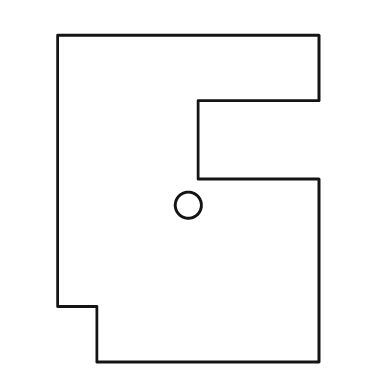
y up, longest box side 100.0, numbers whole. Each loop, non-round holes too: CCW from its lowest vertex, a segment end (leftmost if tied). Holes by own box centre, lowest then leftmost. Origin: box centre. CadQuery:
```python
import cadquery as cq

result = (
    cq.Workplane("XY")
    .moveTo(-28.0, -50.0)
    .lineTo(40.0, -50.0)
    .lineTo(40.0, 6.0)
    .lineTo(3.0, 6.0)
    .lineTo(3.0, 30.0)
    .lineTo(40.0, 30.0)
    .lineTo(40.0, 50.0)
    .lineTo(-40.0, 50.0)
    .lineTo(-40.0, -33.0)
    .lineTo(-28.0, -33.0)
    .close()
    .moveTo(0.0, -2.0)
    .circle(4.0)
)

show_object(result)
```